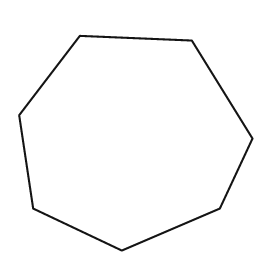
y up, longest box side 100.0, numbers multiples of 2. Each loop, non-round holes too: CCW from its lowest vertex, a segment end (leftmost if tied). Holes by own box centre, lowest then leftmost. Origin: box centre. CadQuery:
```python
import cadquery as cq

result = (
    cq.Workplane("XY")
    .moveTo(-6.0, -46.0)
    .lineTo(36.0, -28.0)
    .lineTo(50.0, 2.0)
    .lineTo(24.0, 44.0)
    .lineTo(-24.0, 46.0)
    .lineTo(-50.0, 12.0)
    .lineTo(-44.0, -28.0)
    .close()
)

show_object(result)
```